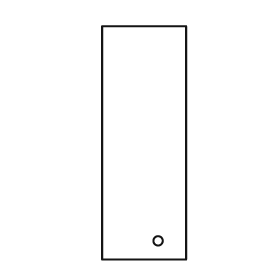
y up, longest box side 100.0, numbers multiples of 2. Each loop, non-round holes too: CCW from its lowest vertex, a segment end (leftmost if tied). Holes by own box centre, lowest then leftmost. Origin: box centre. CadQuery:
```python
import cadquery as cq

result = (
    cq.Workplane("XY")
    .moveTo(-18.0, -50.0)
    .lineTo(18.0, -50.0)
    .lineTo(18.0, 50.0)
    .lineTo(-18.0, 50.0)
    .close()
    .moveTo(6.0, -42.0)
    .circle(2.0)
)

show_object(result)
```